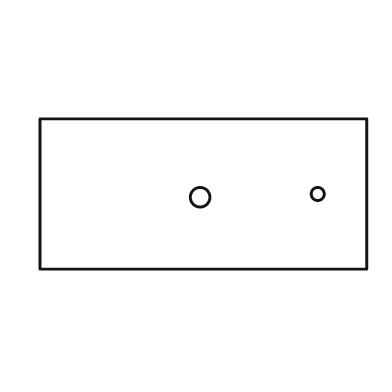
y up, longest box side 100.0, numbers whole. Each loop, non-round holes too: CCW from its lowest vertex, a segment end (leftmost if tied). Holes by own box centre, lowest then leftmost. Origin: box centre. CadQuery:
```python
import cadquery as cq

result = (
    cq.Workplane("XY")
    .moveTo(-50.0, -23.0)
    .lineTo(50.0, -23.0)
    .lineTo(50.0, 23.0)
    .lineTo(-50.0, 23.0)
    .close()
    .moveTo(-1.0, -1.0)
    .circle(3.0)
    .moveTo(35.0, 0.0)
    .circle(2.0)
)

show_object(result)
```